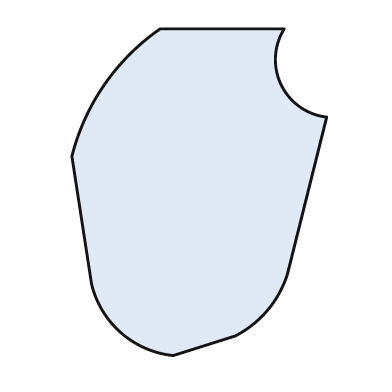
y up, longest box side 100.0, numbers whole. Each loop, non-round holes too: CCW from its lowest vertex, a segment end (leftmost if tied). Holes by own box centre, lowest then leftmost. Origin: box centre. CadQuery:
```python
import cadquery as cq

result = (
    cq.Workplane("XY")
    .moveTo(-8.0, -50.0)
    .lineTo(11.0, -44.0)
    .threePointArc((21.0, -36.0), (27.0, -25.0))
    .lineTo(39.0, 23.0)
    .threePointArc((25.0, 33.0), (26.0, 50.0))
    .lineTo(-12.0, 50.0)
    .threePointArc((-29.0, 33.0), (-39.0, 11.0))
    .lineTo(-33.0, -28.0)
    .threePointArc((-24.0, -43.0), (-8.0, -50.0))
    .close()
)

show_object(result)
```